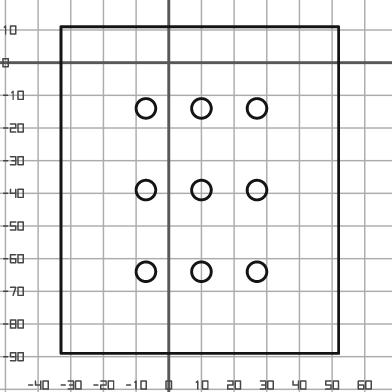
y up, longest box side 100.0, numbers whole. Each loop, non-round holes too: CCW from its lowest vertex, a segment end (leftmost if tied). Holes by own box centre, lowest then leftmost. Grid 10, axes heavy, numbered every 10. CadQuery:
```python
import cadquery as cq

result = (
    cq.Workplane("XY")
    .moveTo(-33.0, -89.0)
    .lineTo(52.0, -89.0)
    .lineTo(52.0, 11.0)
    .lineTo(-33.0, 11.0)
    .close()
    .moveTo(-7.0, -64.0)
    .circle(3.0)
    .moveTo(10.0, -64.0)
    .circle(3.0)
    .moveTo(27.0, -64.0)
    .circle(3.0)
    .moveTo(-7.0, -39.0)
    .circle(3.0)
    .moveTo(10.0, -39.0)
    .circle(3.0)
    .moveTo(27.0, -39.0)
    .circle(3.0)
    .moveTo(-7.0, -14.0)
    .circle(3.0)
    .moveTo(10.0, -14.0)
    .circle(3.0)
    .moveTo(27.0, -14.0)
    .circle(3.0)
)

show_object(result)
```